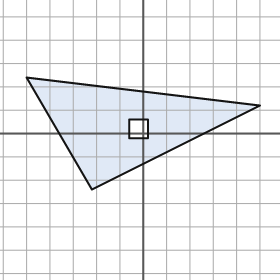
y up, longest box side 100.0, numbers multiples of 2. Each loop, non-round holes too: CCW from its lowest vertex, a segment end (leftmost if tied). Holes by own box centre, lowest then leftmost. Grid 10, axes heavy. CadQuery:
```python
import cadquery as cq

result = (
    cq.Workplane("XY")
    .moveTo(-22.0, -24.0)
    .lineTo(50.0, 12.0)
    .lineTo(-50.0, 24.0)
    .close()
    .moveTo(-6.0, -2.0)
    .lineTo(2.0, -2.0)
    .lineTo(2.0, 6.0)
    .lineTo(-6.0, 6.0)
    .close()
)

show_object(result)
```